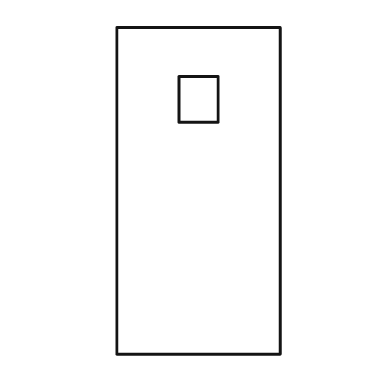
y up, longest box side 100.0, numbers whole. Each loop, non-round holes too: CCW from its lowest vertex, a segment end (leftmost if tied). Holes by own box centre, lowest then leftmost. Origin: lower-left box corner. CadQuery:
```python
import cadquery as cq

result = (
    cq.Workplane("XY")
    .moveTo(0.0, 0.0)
    .lineTo(50.0, 0.0)
    .lineTo(50.0, 100.0)
    .lineTo(0.0, 100.0)
    .close()
    .moveTo(19.0, 71.0)
    .lineTo(31.0, 71.0)
    .lineTo(31.0, 85.0)
    .lineTo(19.0, 85.0)
    .close()
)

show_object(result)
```